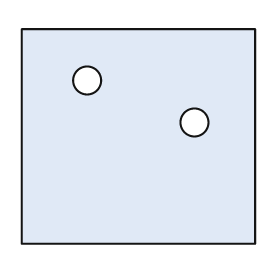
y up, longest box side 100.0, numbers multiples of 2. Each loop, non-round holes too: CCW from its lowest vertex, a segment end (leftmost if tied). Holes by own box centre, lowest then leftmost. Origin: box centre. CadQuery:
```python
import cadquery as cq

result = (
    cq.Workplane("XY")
    .moveTo(-50.0, -46.0)
    .lineTo(50.0, -46.0)
    .lineTo(50.0, 46.0)
    .lineTo(-50.0, 46.0)
    .close()
    .moveTo(24.0, 6.0)
    .circle(6.0)
    .moveTo(-22.0, 24.0)
    .circle(6.0)
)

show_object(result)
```